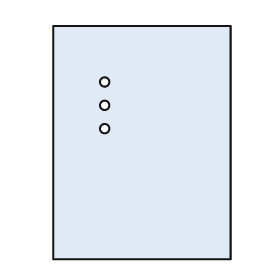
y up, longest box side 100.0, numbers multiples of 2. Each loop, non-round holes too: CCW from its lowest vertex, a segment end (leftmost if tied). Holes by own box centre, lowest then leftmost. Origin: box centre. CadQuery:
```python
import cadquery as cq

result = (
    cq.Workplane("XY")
    .moveTo(-38.0, -50.0)
    .lineTo(38.0, -50.0)
    .lineTo(38.0, 50.0)
    .lineTo(-38.0, 50.0)
    .close()
    .moveTo(-16.0, 6.0)
    .circle(2.0)
    .moveTo(-16.0, 16.0)
    .circle(2.0)
    .moveTo(-16.0, 26.0)
    .circle(2.0)
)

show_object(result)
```